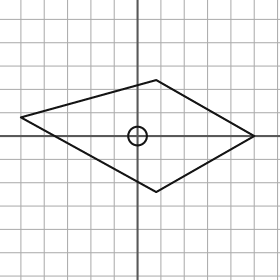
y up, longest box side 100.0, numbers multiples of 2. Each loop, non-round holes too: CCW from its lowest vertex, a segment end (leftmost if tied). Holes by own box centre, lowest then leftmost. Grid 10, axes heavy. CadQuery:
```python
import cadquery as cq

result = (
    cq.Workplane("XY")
    .moveTo(8.0, -24.0)
    .lineTo(50.0, 0.0)
    .lineTo(8.0, 24.0)
    .lineTo(-50.0, 8.0)
    .close()
    .moveTo(0.0, 0.0)
    .circle(4.0)
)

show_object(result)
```